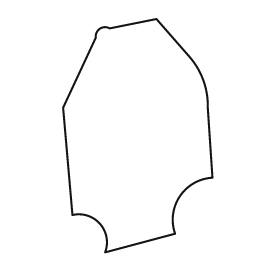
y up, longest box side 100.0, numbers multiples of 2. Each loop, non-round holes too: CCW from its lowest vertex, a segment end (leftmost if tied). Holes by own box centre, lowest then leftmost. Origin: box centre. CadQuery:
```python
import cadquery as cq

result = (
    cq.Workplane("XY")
    .moveTo(-14.0, -50.0)
    .lineTo(16.0, -42.0)
    .threePointArc((18.0, -26.0), (32.0, -18.0))
    .lineTo(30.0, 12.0)
    .threePointArc((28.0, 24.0), (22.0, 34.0))
    .lineTo(8.0, 50.0)
    .lineTo(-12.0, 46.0)
    .threePointArc((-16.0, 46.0), (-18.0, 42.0))
    .lineTo(-32.0, 12.0)
    .lineTo(-28.0, -34.0)
    .threePointArc((-16.0, -38.0), (-14.0, -50.0))
    .close()
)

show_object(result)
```